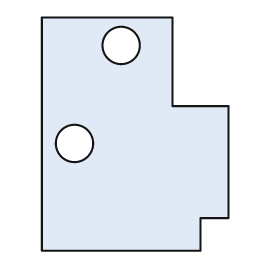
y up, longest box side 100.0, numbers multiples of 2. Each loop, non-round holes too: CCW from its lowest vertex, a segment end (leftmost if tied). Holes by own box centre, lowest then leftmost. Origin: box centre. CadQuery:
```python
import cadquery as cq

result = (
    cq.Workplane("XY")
    .moveTo(-40.0, -50.0)
    .lineTo(28.0, -50.0)
    .lineTo(28.0, -36.0)
    .lineTo(40.0, -36.0)
    .lineTo(40.0, 12.0)
    .lineTo(16.0, 12.0)
    .lineTo(16.0, 50.0)
    .lineTo(-40.0, 50.0)
    .close()
    .moveTo(-26.0, -4.0)
    .circle(8.0)
    .moveTo(-6.0, 38.0)
    .circle(8.0)
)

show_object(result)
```